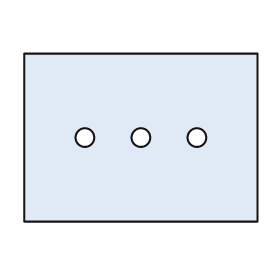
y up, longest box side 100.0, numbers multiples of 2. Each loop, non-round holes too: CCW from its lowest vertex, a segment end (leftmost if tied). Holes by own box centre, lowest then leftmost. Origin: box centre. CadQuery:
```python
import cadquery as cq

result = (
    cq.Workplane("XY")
    .moveTo(-50.0, -36.0)
    .lineTo(50.0, -36.0)
    .lineTo(50.0, 36.0)
    .lineTo(-50.0, 36.0)
    .close()
    .moveTo(-24.0, 0.0)
    .circle(4.0)
    .moveTo(0.0, 0.0)
    .circle(4.0)
    .moveTo(24.0, 0.0)
    .circle(4.0)
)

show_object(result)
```